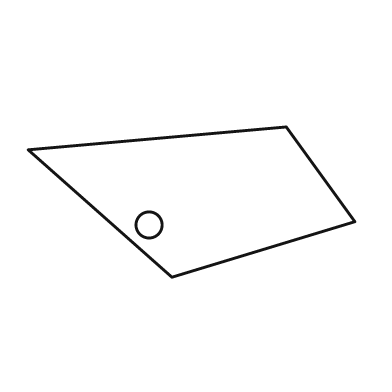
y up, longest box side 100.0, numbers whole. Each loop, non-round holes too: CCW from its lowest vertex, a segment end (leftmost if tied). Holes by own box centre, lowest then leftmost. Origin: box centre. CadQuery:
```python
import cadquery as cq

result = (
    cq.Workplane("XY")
    .moveTo(-6.0, -23.0)
    .lineTo(50.0, -6.0)
    .lineTo(29.0, 23.0)
    .lineTo(-50.0, 16.0)
    .close()
    .moveTo(-13.0, -7.0)
    .circle(4.0)
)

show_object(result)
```